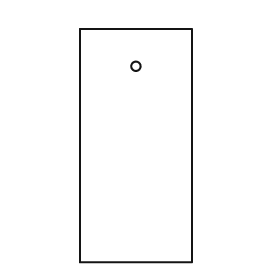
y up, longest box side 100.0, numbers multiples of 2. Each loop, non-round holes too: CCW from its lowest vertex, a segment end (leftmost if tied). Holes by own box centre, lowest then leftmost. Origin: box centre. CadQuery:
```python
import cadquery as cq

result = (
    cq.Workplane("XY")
    .moveTo(-24.0, -50.0)
    .lineTo(24.0, -50.0)
    .lineTo(24.0, 50.0)
    .lineTo(-24.0, 50.0)
    .close()
    .moveTo(0.0, 34.0)
    .circle(2.0)
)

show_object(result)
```